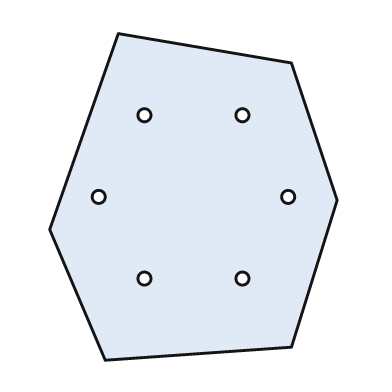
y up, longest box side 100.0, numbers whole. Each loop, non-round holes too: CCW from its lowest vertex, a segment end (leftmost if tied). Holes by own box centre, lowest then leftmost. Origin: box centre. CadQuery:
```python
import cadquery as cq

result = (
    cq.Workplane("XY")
    .moveTo(-27.0, -50.0)
    .lineTo(30.0, -46.0)
    .lineTo(44.0, -1.0)
    .lineTo(30.0, 41.0)
    .lineTo(-23.0, 50.0)
    .lineTo(-44.0, -10.0)
    .close()
    .moveTo(-15.0, -25.0)
    .circle(2.0)
    .moveTo(15.0, -25.0)
    .circle(2.0)
    .moveTo(-29.0, 0.0)
    .circle(2.0)
    .moveTo(29.0, 0.0)
    .circle(2.0)
    .moveTo(-15.0, 25.0)
    .circle(2.0)
    .moveTo(15.0, 25.0)
    .circle(2.0)
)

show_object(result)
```